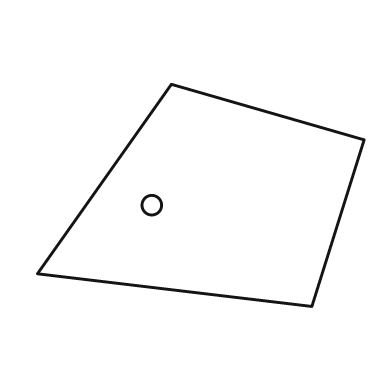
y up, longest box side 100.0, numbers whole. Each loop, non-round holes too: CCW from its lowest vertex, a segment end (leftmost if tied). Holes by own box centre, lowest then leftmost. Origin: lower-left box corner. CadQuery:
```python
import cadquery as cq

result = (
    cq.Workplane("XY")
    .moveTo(84.0, 0.0)
    .lineTo(100.0, 51.0)
    .lineTo(41.0, 68.0)
    .lineTo(0.0, 10.0)
    .close()
    .moveTo(35.0, 31.0)
    .circle(3.0)
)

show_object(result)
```